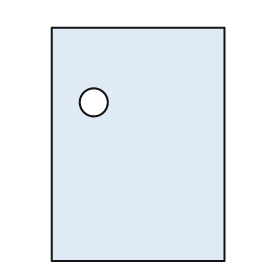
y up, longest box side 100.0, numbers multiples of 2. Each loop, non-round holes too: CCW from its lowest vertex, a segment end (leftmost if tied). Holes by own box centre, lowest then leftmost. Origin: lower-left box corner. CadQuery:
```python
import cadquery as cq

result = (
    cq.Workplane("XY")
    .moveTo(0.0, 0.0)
    .lineTo(74.0, 0.0)
    .lineTo(74.0, 100.0)
    .lineTo(0.0, 100.0)
    .close()
    .moveTo(18.0, 68.0)
    .circle(6.0)
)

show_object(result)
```